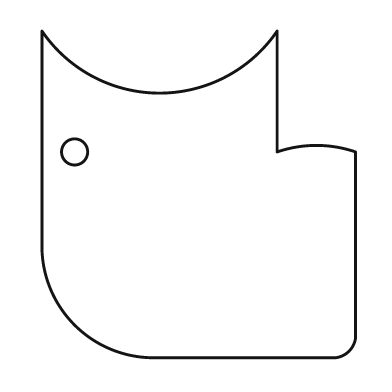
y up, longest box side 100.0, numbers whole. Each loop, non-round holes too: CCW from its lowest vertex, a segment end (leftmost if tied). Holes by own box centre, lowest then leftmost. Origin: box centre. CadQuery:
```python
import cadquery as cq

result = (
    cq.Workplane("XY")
    .moveTo(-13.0, -50.0)
    .lineTo(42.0, -50.0)
    .threePointArc((46.0, -48.0), (48.0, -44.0))
    .lineTo(48.0, 13.0)
    .threePointArc((36.0, 15.0), (24.0, 13.0))
    .lineTo(24.0, 50.0)
    .threePointArc((-12.0, 31.0), (-48.0, 50.0))
    .lineTo(-48.0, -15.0)
    .threePointArc((-38.0, -40.0), (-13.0, -50.0))
    .close()
    .moveTo(-38.0, 13.0)
    .circle(4.0)
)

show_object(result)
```